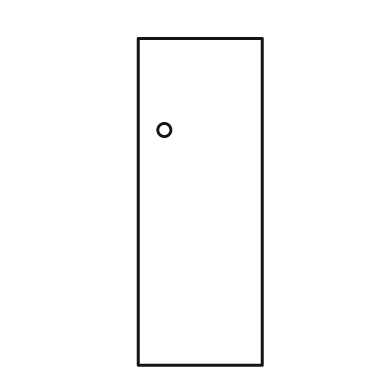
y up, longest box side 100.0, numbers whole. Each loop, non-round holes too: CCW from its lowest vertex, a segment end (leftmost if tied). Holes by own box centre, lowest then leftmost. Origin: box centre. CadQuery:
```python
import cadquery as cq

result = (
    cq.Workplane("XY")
    .moveTo(-19.0, -50.0)
    .lineTo(19.0, -50.0)
    .lineTo(19.0, 50.0)
    .lineTo(-19.0, 50.0)
    .close()
    .moveTo(-11.0, 22.0)
    .circle(2.0)
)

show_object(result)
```